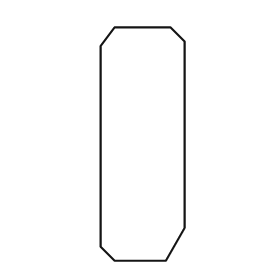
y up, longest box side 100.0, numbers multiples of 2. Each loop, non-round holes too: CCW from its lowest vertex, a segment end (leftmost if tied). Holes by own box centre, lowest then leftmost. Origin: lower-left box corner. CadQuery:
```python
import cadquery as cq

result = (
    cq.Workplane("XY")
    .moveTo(6.0, 0.0)
    .lineTo(28.0, 0.0)
    .lineTo(36.0, 14.0)
    .lineTo(36.0, 94.0)
    .lineTo(30.0, 100.0)
    .lineTo(6.0, 100.0)
    .lineTo(0.0, 92.0)
    .lineTo(0.0, 6.0)
    .close()
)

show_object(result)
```